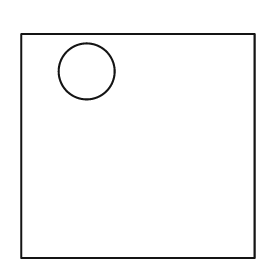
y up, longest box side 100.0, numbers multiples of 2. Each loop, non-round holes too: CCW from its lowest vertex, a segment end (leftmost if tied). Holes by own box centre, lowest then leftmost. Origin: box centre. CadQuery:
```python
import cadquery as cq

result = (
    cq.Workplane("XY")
    .moveTo(-50.0, -48.0)
    .lineTo(50.0, -48.0)
    .lineTo(50.0, 48.0)
    .lineTo(-50.0, 48.0)
    .close()
    .moveTo(-22.0, 32.0)
    .circle(12.0)
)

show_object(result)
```